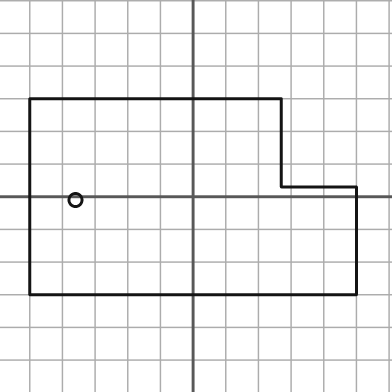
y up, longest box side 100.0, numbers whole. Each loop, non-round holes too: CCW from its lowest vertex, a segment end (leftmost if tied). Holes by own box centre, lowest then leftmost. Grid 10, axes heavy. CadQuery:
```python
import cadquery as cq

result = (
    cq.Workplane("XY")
    .moveTo(-50.0, -30.0)
    .lineTo(50.0, -30.0)
    .lineTo(50.0, 3.0)
    .lineTo(27.0, 3.0)
    .lineTo(27.0, 30.0)
    .lineTo(-50.0, 30.0)
    .close()
    .moveTo(-36.0, -1.0)
    .circle(2.0)
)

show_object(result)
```